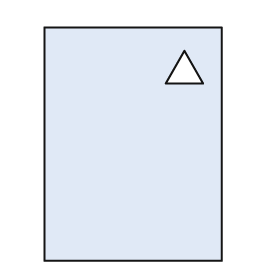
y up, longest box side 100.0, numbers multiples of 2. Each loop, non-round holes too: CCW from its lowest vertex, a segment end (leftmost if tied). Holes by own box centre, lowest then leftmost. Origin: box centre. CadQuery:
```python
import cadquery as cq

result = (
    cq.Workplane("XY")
    .moveTo(-38.0, -50.0)
    .lineTo(38.0, -50.0)
    .lineTo(38.0, 50.0)
    .lineTo(-38.0, 50.0)
    .close()
    .moveTo(14.0, 26.0)
    .lineTo(30.0, 26.0)
    .lineTo(22.0, 40.0)
    .close()
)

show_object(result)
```